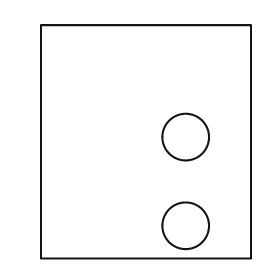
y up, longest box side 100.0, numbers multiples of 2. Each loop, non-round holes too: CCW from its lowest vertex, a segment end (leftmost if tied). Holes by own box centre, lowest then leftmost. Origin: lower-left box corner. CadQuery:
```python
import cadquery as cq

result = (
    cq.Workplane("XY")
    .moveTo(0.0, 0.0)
    .lineTo(90.0, 0.0)
    .lineTo(90.0, 100.0)
    .lineTo(0.0, 100.0)
    .close()
    .moveTo(62.0, 14.0)
    .circle(10.0)
    .moveTo(62.0, 52.0)
    .circle(10.0)
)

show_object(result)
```